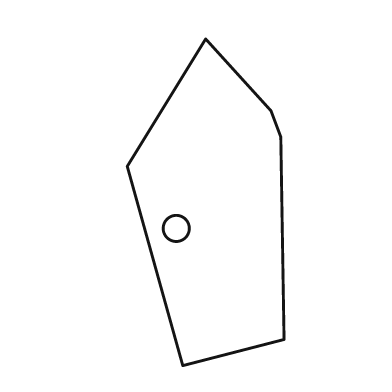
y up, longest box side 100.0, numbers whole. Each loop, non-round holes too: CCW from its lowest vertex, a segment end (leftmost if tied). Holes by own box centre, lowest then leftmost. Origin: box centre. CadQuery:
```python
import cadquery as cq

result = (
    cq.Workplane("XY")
    .moveTo(-7.0, -50.0)
    .lineTo(24.0, -42.0)
    .lineTo(23.0, 20.0)
    .lineTo(20.0, 28.0)
    .lineTo(0.0, 50.0)
    .lineTo(-24.0, 11.0)
    .close()
    .moveTo(-9.0, -8.0)
    .circle(4.0)
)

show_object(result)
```